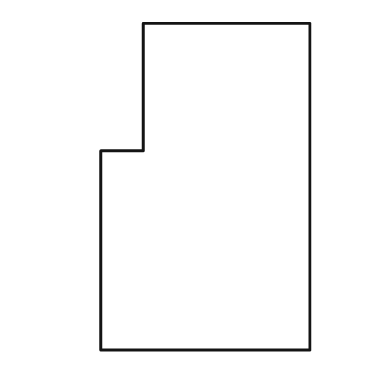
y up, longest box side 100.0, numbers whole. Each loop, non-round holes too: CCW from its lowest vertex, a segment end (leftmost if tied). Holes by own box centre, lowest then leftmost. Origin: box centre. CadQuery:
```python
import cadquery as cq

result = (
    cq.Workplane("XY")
    .moveTo(-32.0, -50.0)
    .lineTo(32.0, -50.0)
    .lineTo(32.0, 50.0)
    .lineTo(-19.0, 50.0)
    .lineTo(-19.0, 11.0)
    .lineTo(-32.0, 11.0)
    .close()
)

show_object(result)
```